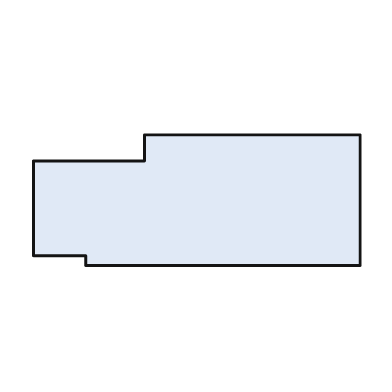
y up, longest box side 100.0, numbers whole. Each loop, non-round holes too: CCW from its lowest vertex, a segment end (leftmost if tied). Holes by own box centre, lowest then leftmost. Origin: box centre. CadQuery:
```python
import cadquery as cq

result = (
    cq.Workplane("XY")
    .moveTo(-34.0, -20.0)
    .lineTo(50.0, -20.0)
    .lineTo(50.0, 20.0)
    .lineTo(-16.0, 20.0)
    .lineTo(-16.0, 12.0)
    .lineTo(-50.0, 12.0)
    .lineTo(-50.0, -17.0)
    .lineTo(-34.0, -17.0)
    .close()
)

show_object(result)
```